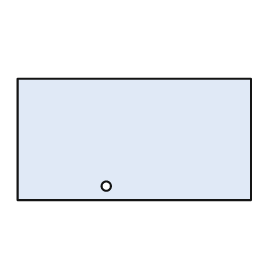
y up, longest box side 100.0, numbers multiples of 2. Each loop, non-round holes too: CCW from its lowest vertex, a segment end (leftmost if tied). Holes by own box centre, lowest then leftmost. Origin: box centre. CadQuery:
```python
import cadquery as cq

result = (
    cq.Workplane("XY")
    .moveTo(-50.0, -26.0)
    .lineTo(50.0, -26.0)
    .lineTo(50.0, 26.0)
    .lineTo(-50.0, 26.0)
    .close()
    .moveTo(-12.0, -20.0)
    .circle(2.0)
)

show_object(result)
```